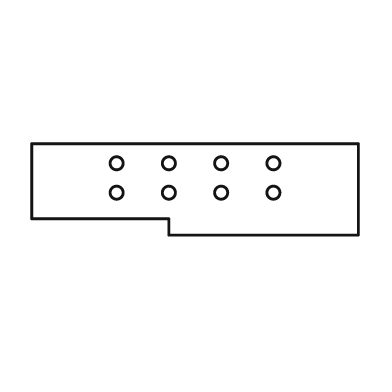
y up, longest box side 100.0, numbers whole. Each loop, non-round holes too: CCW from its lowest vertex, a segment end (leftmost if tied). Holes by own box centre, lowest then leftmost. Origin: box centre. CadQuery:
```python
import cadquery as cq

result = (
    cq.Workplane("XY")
    .moveTo(-8.0, -14.0)
    .lineTo(50.0, -14.0)
    .lineTo(50.0, 14.0)
    .lineTo(-50.0, 14.0)
    .lineTo(-50.0, -9.0)
    .lineTo(-8.0, -9.0)
    .close()
    .moveTo(-24.0, -1.0)
    .circle(2.0)
    .moveTo(-8.0, -1.0)
    .circle(2.0)
    .moveTo(8.0, -1.0)
    .circle(2.0)
    .moveTo(24.0, -1.0)
    .circle(2.0)
    .moveTo(-24.0, 8.0)
    .circle(2.0)
    .moveTo(-8.0, 8.0)
    .circle(2.0)
    .moveTo(8.0, 8.0)
    .circle(2.0)
    .moveTo(24.0, 8.0)
    .circle(2.0)
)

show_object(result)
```